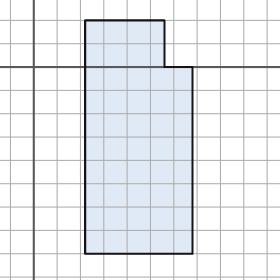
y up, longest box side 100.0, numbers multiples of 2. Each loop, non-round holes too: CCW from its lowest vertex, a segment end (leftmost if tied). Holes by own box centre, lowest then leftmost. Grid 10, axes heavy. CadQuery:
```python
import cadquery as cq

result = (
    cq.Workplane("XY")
    .moveTo(22.0, -80.0)
    .lineTo(68.0, -80.0)
    .lineTo(68.0, 0.0)
    .lineTo(56.0, 0.0)
    .lineTo(56.0, 20.0)
    .lineTo(22.0, 20.0)
    .close()
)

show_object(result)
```